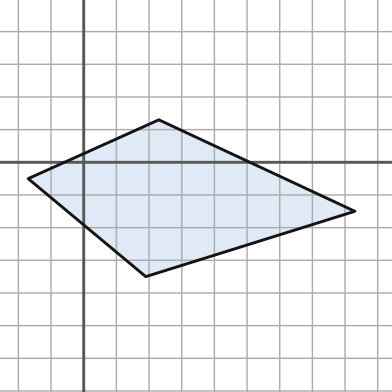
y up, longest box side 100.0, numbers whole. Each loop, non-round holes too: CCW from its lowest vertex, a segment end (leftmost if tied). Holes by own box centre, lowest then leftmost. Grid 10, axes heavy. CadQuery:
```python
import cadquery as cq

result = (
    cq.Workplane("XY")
    .moveTo(19.0, -35.0)
    .lineTo(83.0, -15.0)
    .lineTo(23.0, 13.0)
    .lineTo(-17.0, -5.0)
    .close()
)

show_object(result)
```